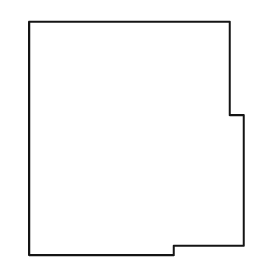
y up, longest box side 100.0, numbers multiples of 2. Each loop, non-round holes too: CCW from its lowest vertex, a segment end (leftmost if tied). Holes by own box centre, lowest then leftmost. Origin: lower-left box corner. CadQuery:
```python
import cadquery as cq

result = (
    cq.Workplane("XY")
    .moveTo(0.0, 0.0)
    .lineTo(62.0, 0.0)
    .lineTo(62.0, 4.0)
    .lineTo(92.0, 4.0)
    .lineTo(92.0, 60.0)
    .lineTo(86.0, 60.0)
    .lineTo(86.0, 100.0)
    .lineTo(0.0, 100.0)
    .close()
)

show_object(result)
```